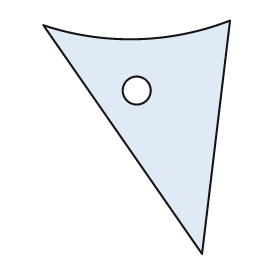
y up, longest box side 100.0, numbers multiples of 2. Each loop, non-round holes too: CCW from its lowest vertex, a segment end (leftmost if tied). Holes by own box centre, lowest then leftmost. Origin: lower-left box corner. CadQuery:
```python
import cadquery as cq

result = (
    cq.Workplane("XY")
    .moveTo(68.0, 0.0)
    .lineTo(80.0, 100.0)
    .threePointArc((40.0, 92.0), (0.0, 98.0))
    .close()
    .moveTo(40.0, 70.0)
    .circle(6.0)
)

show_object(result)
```